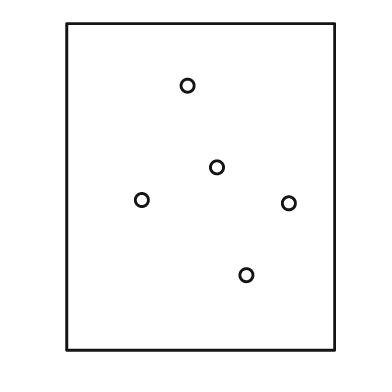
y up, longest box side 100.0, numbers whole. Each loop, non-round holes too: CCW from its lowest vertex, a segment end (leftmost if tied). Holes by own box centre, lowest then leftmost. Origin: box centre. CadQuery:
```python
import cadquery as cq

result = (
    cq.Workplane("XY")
    .moveTo(-41.0, -50.0)
    .lineTo(41.0, -50.0)
    .lineTo(41.0, 50.0)
    .lineTo(-41.0, 50.0)
    .close()
    .moveTo(14.0, -27.0)
    .circle(2.0)
    .moveTo(27.0, -5.0)
    .circle(2.0)
    .moveTo(-18.0, -4.0)
    .circle(2.0)
    .moveTo(5.0, 6.0)
    .circle(2.0)
    .moveTo(-4.0, 31.0)
    .circle(2.0)
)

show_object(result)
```